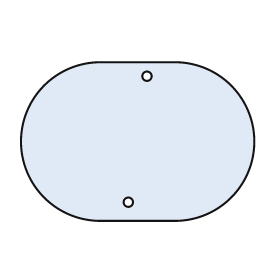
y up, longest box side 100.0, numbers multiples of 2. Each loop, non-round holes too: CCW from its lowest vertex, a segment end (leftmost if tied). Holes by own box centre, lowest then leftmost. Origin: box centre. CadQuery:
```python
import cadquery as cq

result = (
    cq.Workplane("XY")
    .moveTo(-16.0, -34.0)
    .lineTo(16.0, -34.0)
    .threePointArc((50.0, 0.0), (16.0, 34.0))
    .lineTo(-16.0, 34.0)
    .threePointArc((-50.0, 0.0), (-16.0, -34.0))
    .close()
    .moveTo(-4.0, -26.0)
    .circle(2.0)
    .moveTo(4.0, 28.0)
    .circle(2.0)
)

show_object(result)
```